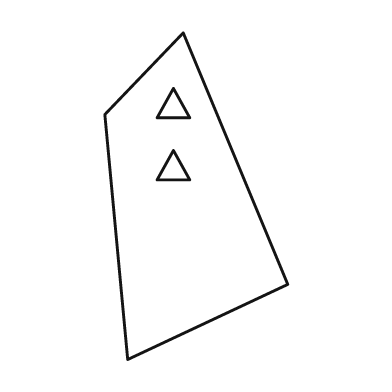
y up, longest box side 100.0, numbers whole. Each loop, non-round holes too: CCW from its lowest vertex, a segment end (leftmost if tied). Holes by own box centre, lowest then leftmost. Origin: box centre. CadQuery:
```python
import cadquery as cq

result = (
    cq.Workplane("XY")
    .moveTo(-21.0, -50.0)
    .lineTo(28.0, -27.0)
    .lineTo(-4.0, 50.0)
    .lineTo(-28.0, 25.0)
    .close()
    .moveTo(-12.0, 5.0)
    .lineTo(-2.0, 5.0)
    .lineTo(-7.0, 14.0)
    .close()
    .moveTo(-12.0, 24.0)
    .lineTo(-2.0, 24.0)
    .lineTo(-7.0, 33.0)
    .close()
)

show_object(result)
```